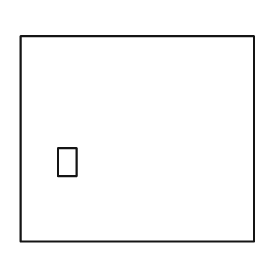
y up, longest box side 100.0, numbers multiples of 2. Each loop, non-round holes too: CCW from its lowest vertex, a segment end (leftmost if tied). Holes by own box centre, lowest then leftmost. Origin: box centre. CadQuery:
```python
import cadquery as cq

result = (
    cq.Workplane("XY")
    .moveTo(-50.0, -44.0)
    .lineTo(50.0, -44.0)
    .lineTo(50.0, 44.0)
    .lineTo(-50.0, 44.0)
    .close()
    .moveTo(-34.0, -16.0)
    .lineTo(-26.0, -16.0)
    .lineTo(-26.0, -4.0)
    .lineTo(-34.0, -4.0)
    .close()
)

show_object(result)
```